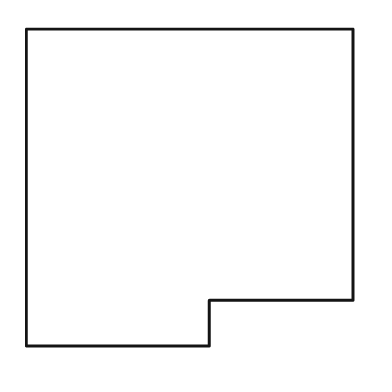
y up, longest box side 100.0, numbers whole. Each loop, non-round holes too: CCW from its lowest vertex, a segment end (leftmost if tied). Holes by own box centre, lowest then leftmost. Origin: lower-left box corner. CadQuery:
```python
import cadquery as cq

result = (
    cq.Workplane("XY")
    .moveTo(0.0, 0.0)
    .lineTo(56.0, 0.0)
    .lineTo(56.0, 14.0)
    .lineTo(100.0, 14.0)
    .lineTo(100.0, 97.0)
    .lineTo(0.0, 97.0)
    .close()
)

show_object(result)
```